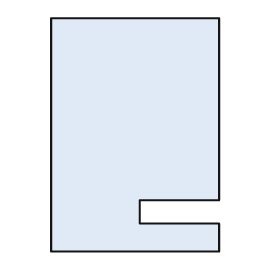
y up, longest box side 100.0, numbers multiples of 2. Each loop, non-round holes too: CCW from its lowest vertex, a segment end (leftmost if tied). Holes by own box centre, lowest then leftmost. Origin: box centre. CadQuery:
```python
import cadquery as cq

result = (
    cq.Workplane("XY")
    .moveTo(-36.0, -50.0)
    .lineTo(36.0, -50.0)
    .lineTo(36.0, -38.0)
    .lineTo(2.0, -38.0)
    .lineTo(2.0, -28.0)
    .lineTo(36.0, -28.0)
    .lineTo(36.0, 50.0)
    .lineTo(-36.0, 50.0)
    .close()
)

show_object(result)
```